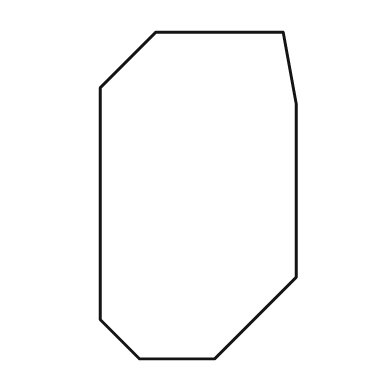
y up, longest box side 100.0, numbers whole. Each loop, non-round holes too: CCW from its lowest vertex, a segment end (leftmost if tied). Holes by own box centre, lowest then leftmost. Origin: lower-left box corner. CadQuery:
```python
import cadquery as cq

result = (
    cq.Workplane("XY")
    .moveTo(12.0, 0.0)
    .lineTo(35.0, 0.0)
    .lineTo(60.0, 25.0)
    .lineTo(60.0, 78.0)
    .lineTo(56.0, 100.0)
    .lineTo(17.0, 100.0)
    .lineTo(0.0, 83.0)
    .lineTo(0.0, 12.0)
    .close()
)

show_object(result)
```